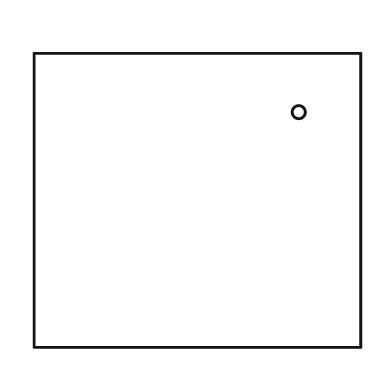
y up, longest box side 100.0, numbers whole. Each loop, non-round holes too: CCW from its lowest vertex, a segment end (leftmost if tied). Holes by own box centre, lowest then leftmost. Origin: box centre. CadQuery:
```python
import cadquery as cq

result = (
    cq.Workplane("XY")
    .moveTo(-50.0, -45.0)
    .lineTo(50.0, -45.0)
    .lineTo(50.0, 45.0)
    .lineTo(-50.0, 45.0)
    .close()
    .moveTo(31.0, 27.0)
    .circle(2.0)
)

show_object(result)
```